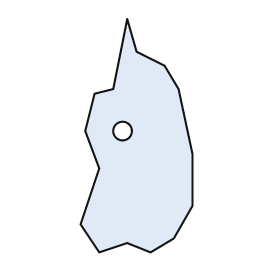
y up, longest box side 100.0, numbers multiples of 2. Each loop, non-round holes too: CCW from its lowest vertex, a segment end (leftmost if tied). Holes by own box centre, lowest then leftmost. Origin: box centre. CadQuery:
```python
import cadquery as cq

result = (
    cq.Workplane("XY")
    .moveTo(-16.0, -50.0)
    .lineTo(-4.0, -46.0)
    .lineTo(6.0, -50.0)
    .lineTo(16.0, -44.0)
    .lineTo(24.0, -30.0)
    .lineTo(24.0, -8.0)
    .lineTo(18.0, 20.0)
    .lineTo(12.0, 30.0)
    .lineTo(0.0, 36.0)
    .lineTo(-4.0, 50.0)
    .lineTo(-10.0, 20.0)
    .lineTo(-18.0, 18.0)
    .lineTo(-22.0, 2.0)
    .lineTo(-16.0, -14.0)
    .lineTo(-24.0, -38.0)
    .close()
    .moveTo(-6.0, 2.0)
    .circle(4.0)
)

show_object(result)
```